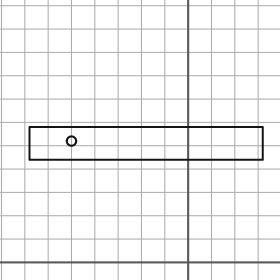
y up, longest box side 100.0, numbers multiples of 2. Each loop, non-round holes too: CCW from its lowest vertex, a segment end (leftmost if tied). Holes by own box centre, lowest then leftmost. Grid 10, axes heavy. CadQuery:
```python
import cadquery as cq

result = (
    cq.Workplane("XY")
    .moveTo(-68.0, 44.0)
    .lineTo(32.0, 44.0)
    .lineTo(32.0, 58.0)
    .lineTo(-68.0, 58.0)
    .close()
    .moveTo(-50.0, 52.0)
    .circle(2.0)
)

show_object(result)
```